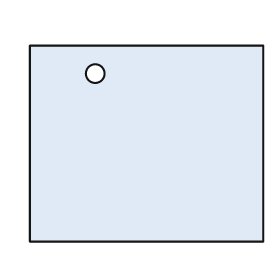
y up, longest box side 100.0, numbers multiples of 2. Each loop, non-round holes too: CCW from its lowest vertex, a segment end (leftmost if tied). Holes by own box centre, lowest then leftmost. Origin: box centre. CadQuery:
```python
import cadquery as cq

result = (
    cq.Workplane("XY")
    .moveTo(-50.0, -42.0)
    .lineTo(50.0, -42.0)
    .lineTo(50.0, 42.0)
    .lineTo(-50.0, 42.0)
    .close()
    .moveTo(-22.0, 30.0)
    .circle(4.0)
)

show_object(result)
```